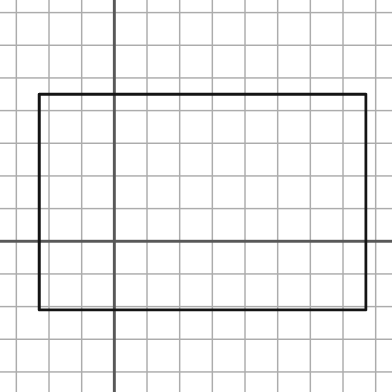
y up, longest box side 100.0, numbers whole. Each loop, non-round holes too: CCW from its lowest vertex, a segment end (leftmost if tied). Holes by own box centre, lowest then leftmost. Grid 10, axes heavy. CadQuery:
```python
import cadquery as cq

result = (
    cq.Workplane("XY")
    .moveTo(-23.0, -21.0)
    .lineTo(77.0, -21.0)
    .lineTo(77.0, 45.0)
    .lineTo(-23.0, 45.0)
    .close()
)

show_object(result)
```